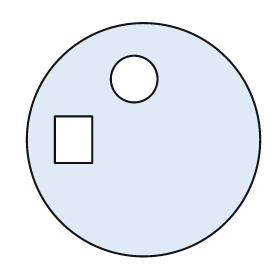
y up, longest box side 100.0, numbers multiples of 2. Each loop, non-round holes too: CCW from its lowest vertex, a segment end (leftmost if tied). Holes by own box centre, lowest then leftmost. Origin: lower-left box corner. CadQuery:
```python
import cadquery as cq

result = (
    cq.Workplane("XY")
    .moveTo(50.0, 50.0)
    .circle(50.0)
    .moveTo(12.0, 40.0)
    .lineTo(28.0, 40.0)
    .lineTo(28.0, 60.0)
    .lineTo(12.0, 60.0)
    .close()
    .moveTo(46.0, 76.0)
    .circle(10.0)
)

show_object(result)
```